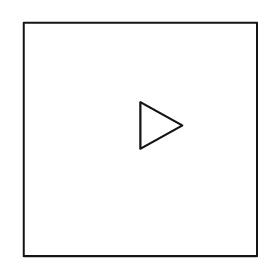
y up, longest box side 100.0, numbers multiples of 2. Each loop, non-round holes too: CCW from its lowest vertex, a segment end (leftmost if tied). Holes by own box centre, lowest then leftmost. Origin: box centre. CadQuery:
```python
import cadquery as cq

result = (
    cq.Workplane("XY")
    .moveTo(-50.0, -50.0)
    .lineTo(50.0, -50.0)
    .lineTo(50.0, 50.0)
    .lineTo(-50.0, 50.0)
    .close()
    .moveTo(0.0, -4.0)
    .lineTo(18.0, 6.0)
    .lineTo(0.0, 16.0)
    .close()
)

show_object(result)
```